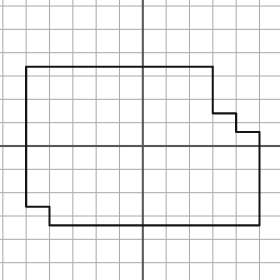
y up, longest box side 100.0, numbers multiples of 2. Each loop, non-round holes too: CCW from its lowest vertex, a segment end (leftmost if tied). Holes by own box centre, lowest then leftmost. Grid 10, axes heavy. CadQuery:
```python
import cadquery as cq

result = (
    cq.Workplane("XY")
    .moveTo(-40.0, -34.0)
    .lineTo(50.0, -34.0)
    .lineTo(50.0, 6.0)
    .lineTo(40.0, 6.0)
    .lineTo(40.0, 14.0)
    .lineTo(30.0, 14.0)
    .lineTo(30.0, 34.0)
    .lineTo(-50.0, 34.0)
    .lineTo(-50.0, -26.0)
    .lineTo(-40.0, -26.0)
    .close()
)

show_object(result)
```